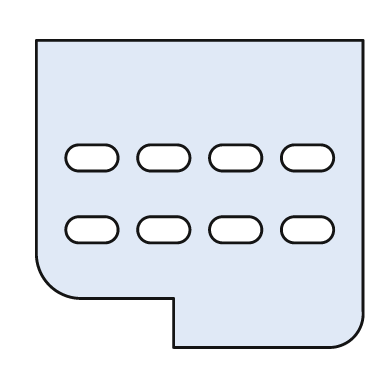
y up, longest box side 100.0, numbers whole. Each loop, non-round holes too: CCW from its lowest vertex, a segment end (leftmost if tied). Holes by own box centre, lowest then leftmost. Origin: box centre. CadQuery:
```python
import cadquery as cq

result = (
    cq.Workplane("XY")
    .moveTo(-8.0, -47.0)
    .lineTo(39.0, -47.0)
    .threePointArc((47.0, -44.0), (50.0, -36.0))
    .lineTo(50.0, 47.0)
    .lineTo(-50.0, 47.0)
    .lineTo(-50.0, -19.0)
    .threePointArc((-46.0, -28.0), (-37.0, -32.0))
    .lineTo(-8.0, -32.0)
    .close()
    .moveTo(-37.0, -15.0)
    .lineTo(-29.0, -15.0)
    .threePointArc((-25.0, -11.0), (-29.0, -7.0))
    .lineTo(-37.0, -7.0)
    .threePointArc((-41.0, -11.0), (-37.0, -15.0))
    .close()
    .moveTo(-15.0, -15.0)
    .lineTo(-7.0, -15.0)
    .threePointArc((-3.0, -11.0), (-7.0, -7.0))
    .lineTo(-15.0, -7.0)
    .threePointArc((-19.0, -11.0), (-15.0, -15.0))
    .close()
    .moveTo(7.0, -15.0)
    .lineTo(15.0, -15.0)
    .threePointArc((19.0, -11.0), (15.0, -7.0))
    .lineTo(7.0, -7.0)
    .threePointArc((3.0, -11.0), (7.0, -15.0))
    .close()
    .moveTo(29.0, -15.0)
    .lineTo(37.0, -15.0)
    .threePointArc((41.0, -11.0), (37.0, -7.0))
    .lineTo(29.0, -7.0)
    .threePointArc((25.0, -11.0), (29.0, -15.0))
    .close()
    .moveTo(-37.0, 7.0)
    .lineTo(-29.0, 7.0)
    .threePointArc((-25.0, 11.0), (-29.0, 15.0))
    .lineTo(-37.0, 15.0)
    .threePointArc((-41.0, 11.0), (-37.0, 7.0))
    .close()
    .moveTo(-15.0, 7.0)
    .lineTo(-7.0, 7.0)
    .threePointArc((-3.0, 11.0), (-7.0, 15.0))
    .lineTo(-15.0, 15.0)
    .threePointArc((-19.0, 11.0), (-15.0, 7.0))
    .close()
    .moveTo(7.0, 7.0)
    .lineTo(15.0, 7.0)
    .threePointArc((19.0, 11.0), (15.0, 15.0))
    .lineTo(7.0, 15.0)
    .threePointArc((3.0, 11.0), (7.0, 7.0))
    .close()
    .moveTo(29.0, 7.0)
    .lineTo(37.0, 7.0)
    .threePointArc((41.0, 11.0), (37.0, 15.0))
    .lineTo(29.0, 15.0)
    .threePointArc((25.0, 11.0), (29.0, 7.0))
    .close()
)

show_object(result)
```